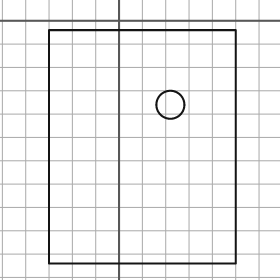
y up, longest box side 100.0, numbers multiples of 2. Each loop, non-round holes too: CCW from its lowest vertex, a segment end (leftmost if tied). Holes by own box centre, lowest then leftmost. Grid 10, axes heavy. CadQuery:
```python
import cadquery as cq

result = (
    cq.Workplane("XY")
    .moveTo(-30.0, -104.0)
    .lineTo(50.0, -104.0)
    .lineTo(50.0, -4.0)
    .lineTo(-30.0, -4.0)
    .close()
    .moveTo(22.0, -36.0)
    .circle(6.0)
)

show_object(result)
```